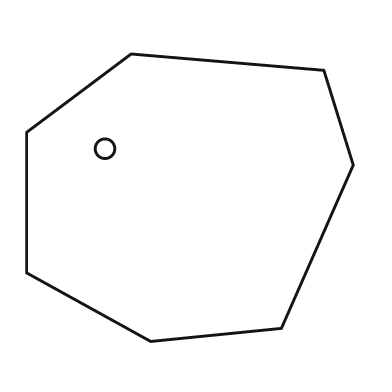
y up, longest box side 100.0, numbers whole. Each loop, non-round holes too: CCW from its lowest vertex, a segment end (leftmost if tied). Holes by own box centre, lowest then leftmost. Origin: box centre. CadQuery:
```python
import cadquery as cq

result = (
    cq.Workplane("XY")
    .moveTo(-12.0, -44.0)
    .lineTo(28.0, -40.0)
    .lineTo(50.0, 10.0)
    .lineTo(41.0, 39.0)
    .lineTo(-18.0, 44.0)
    .lineTo(-50.0, 20.0)
    .lineTo(-50.0, -23.0)
    .close()
    .moveTo(-26.0, 15.0)
    .circle(3.0)
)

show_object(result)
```